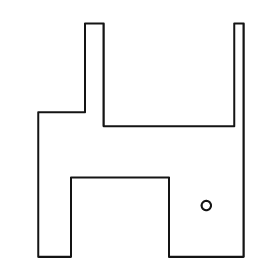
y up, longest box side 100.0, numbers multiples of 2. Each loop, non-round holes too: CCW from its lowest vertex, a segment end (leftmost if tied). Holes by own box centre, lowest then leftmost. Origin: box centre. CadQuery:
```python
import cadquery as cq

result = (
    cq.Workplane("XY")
    .moveTo(-44.0, -50.0)
    .lineTo(-30.0, -50.0)
    .lineTo(-30.0, -16.0)
    .lineTo(12.0, -16.0)
    .lineTo(12.0, -50.0)
    .lineTo(44.0, -50.0)
    .lineTo(44.0, 50.0)
    .lineTo(40.0, 50.0)
    .lineTo(40.0, 6.0)
    .lineTo(-16.0, 6.0)
    .lineTo(-16.0, 50.0)
    .lineTo(-24.0, 50.0)
    .lineTo(-24.0, 12.0)
    .lineTo(-44.0, 12.0)
    .close()
    .moveTo(28.0, -28.0)
    .circle(2.0)
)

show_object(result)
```